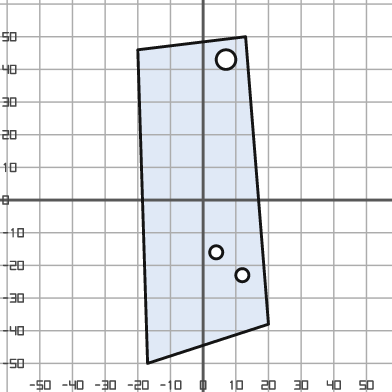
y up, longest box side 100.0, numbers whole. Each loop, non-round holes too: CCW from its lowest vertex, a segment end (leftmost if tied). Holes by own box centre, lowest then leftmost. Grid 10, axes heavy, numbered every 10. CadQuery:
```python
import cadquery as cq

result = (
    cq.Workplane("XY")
    .moveTo(-17.0, -50.0)
    .lineTo(20.0, -38.0)
    .lineTo(13.0, 50.0)
    .lineTo(-20.0, 46.0)
    .close()
    .moveTo(12.0, -23.0)
    .circle(2.0)
    .moveTo(4.0, -16.0)
    .circle(2.0)
    .moveTo(7.0, 43.0)
    .circle(3.0)
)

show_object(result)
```